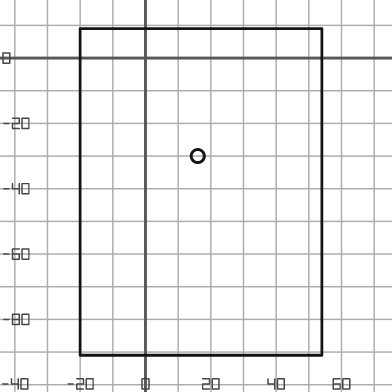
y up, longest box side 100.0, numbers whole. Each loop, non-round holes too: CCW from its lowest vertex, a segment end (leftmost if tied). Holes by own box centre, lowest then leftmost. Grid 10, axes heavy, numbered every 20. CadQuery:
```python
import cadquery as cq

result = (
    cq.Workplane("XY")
    .moveTo(-20.0, -91.0)
    .lineTo(54.0, -91.0)
    .lineTo(54.0, 9.0)
    .lineTo(-20.0, 9.0)
    .close()
    .moveTo(16.0, -30.0)
    .circle(2.0)
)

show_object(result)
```